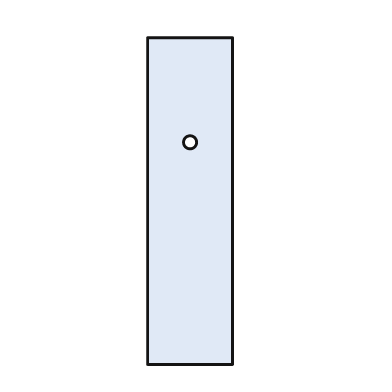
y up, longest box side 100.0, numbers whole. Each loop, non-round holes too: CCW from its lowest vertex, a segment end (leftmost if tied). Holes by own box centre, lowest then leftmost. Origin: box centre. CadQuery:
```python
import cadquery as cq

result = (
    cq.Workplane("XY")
    .moveTo(-13.0, -50.0)
    .lineTo(13.0, -50.0)
    .lineTo(13.0, 50.0)
    .lineTo(-13.0, 50.0)
    .close()
    .moveTo(0.0, 18.0)
    .circle(2.0)
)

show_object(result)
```